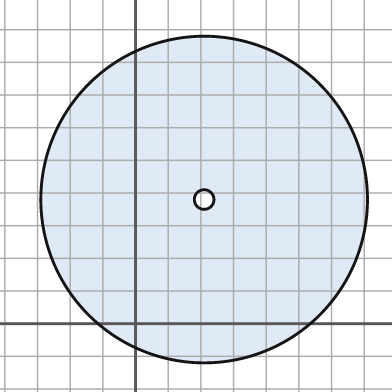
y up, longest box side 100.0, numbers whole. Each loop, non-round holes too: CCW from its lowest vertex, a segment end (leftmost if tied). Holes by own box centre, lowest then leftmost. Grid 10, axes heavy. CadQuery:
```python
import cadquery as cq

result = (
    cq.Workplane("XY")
    .moveTo(21.0, 38.0)
    .circle(50.0)
    .moveTo(21.0, 38.0)
    .circle(3.0)
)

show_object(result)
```